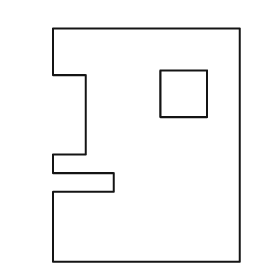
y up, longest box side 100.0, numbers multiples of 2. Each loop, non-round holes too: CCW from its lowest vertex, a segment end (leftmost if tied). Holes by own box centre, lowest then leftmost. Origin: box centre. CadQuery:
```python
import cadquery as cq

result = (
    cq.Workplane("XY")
    .moveTo(-40.0, -50.0)
    .lineTo(40.0, -50.0)
    .lineTo(40.0, 50.0)
    .lineTo(-40.0, 50.0)
    .lineTo(-40.0, 30.0)
    .lineTo(-26.0, 30.0)
    .lineTo(-26.0, -4.0)
    .lineTo(-40.0, -4.0)
    .lineTo(-40.0, -12.0)
    .lineTo(-14.0, -12.0)
    .lineTo(-14.0, -20.0)
    .lineTo(-40.0, -20.0)
    .close()
    .moveTo(6.0, 12.0)
    .lineTo(26.0, 12.0)
    .lineTo(26.0, 32.0)
    .lineTo(6.0, 32.0)
    .close()
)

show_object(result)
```